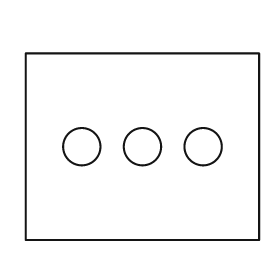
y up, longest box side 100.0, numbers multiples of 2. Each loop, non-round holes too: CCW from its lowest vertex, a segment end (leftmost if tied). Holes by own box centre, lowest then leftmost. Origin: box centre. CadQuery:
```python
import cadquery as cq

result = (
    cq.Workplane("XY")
    .moveTo(-50.0, -40.0)
    .lineTo(50.0, -40.0)
    .lineTo(50.0, 40.0)
    .lineTo(-50.0, 40.0)
    .close()
    .moveTo(-26.0, 0.0)
    .circle(8.0)
    .moveTo(0.0, 0.0)
    .circle(8.0)
    .moveTo(26.0, 0.0)
    .circle(8.0)
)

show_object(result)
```